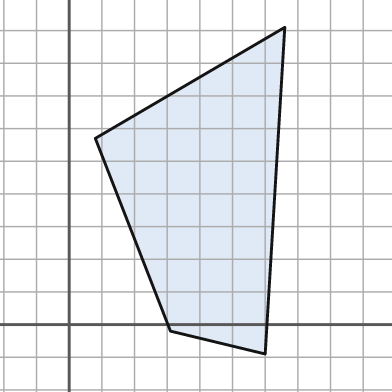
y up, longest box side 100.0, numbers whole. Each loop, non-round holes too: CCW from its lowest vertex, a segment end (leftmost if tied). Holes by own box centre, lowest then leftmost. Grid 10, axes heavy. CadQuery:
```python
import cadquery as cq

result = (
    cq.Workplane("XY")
    .moveTo(60.0, -9.0)
    .lineTo(66.0, 91.0)
    .lineTo(8.0, 57.0)
    .lineTo(31.0, -2.0)
    .close()
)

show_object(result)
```